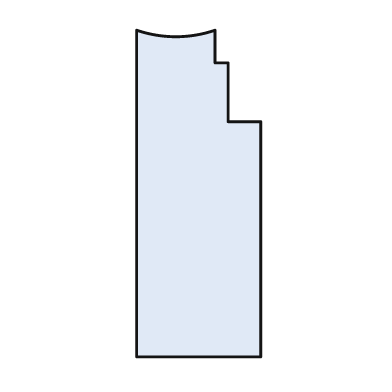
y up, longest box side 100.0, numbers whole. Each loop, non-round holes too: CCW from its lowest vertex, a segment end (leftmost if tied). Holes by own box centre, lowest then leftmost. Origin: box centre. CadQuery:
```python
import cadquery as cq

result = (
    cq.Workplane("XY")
    .moveTo(-19.0, -50.0)
    .lineTo(19.0, -50.0)
    .lineTo(19.0, 22.0)
    .lineTo(9.0, 22.0)
    .lineTo(9.0, 40.0)
    .lineTo(5.0, 40.0)
    .lineTo(5.0, 50.0)
    .threePointArc((-7.0, 48.0), (-19.0, 50.0))
    .close()
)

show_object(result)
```